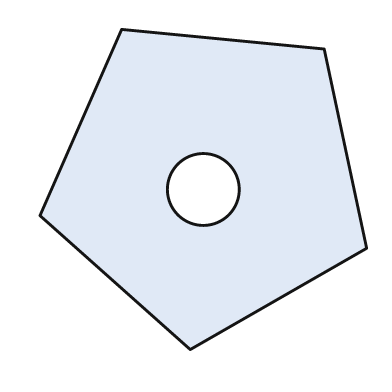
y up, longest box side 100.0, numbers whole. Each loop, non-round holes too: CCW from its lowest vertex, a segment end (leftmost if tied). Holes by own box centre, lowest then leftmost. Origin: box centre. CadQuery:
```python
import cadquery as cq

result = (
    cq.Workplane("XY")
    .moveTo(-4.0, -49.0)
    .lineTo(50.0, -18.0)
    .lineTo(37.0, 43.0)
    .lineTo(-25.0, 49.0)
    .lineTo(-50.0, -8.0)
    .close()
    .moveTo(0.0, 0.0)
    .circle(11.0)
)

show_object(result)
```